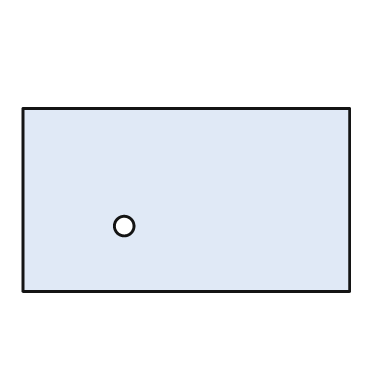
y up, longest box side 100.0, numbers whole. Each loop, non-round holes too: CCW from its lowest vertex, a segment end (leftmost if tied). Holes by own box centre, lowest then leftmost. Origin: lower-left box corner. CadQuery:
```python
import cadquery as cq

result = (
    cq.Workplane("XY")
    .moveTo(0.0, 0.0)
    .lineTo(100.0, 0.0)
    .lineTo(100.0, 56.0)
    .lineTo(0.0, 56.0)
    .close()
    .moveTo(31.0, 20.0)
    .circle(3.0)
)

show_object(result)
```